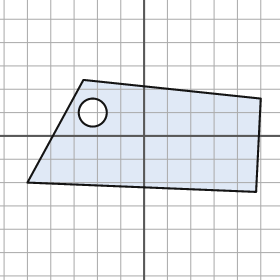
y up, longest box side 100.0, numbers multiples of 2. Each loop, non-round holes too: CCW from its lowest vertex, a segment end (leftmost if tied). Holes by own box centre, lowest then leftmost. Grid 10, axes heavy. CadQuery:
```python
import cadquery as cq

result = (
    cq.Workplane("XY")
    .moveTo(48.0, -24.0)
    .lineTo(50.0, 16.0)
    .lineTo(-26.0, 24.0)
    .lineTo(-50.0, -20.0)
    .close()
    .moveTo(-22.0, 10.0)
    .circle(6.0)
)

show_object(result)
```